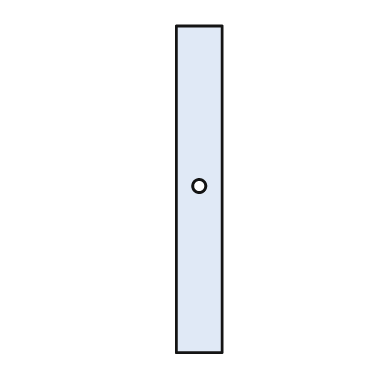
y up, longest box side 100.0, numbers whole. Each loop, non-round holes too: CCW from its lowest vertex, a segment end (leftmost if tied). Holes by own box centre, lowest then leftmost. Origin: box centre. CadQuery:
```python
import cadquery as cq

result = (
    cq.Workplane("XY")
    .moveTo(-7.0, -50.0)
    .lineTo(7.0, -50.0)
    .lineTo(7.0, 50.0)
    .lineTo(-7.0, 50.0)
    .close()
    .moveTo(0.0, 1.0)
    .circle(2.0)
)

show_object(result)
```